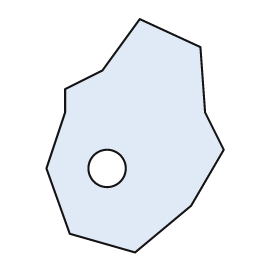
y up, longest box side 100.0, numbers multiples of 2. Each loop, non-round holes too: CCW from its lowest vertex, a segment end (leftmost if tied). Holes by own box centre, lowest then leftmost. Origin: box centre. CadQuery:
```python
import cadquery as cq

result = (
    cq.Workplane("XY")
    .moveTo(0.0, -50.0)
    .lineTo(24.0, -30.0)
    .lineTo(38.0, -6.0)
    .lineTo(30.0, 10.0)
    .lineTo(28.0, 38.0)
    .lineTo(2.0, 50.0)
    .lineTo(-14.0, 28.0)
    .lineTo(-30.0, 20.0)
    .lineTo(-30.0, 10.0)
    .lineTo(-38.0, -14.0)
    .lineTo(-28.0, -42.0)
    .close()
    .moveTo(-12.0, -14.0)
    .circle(8.0)
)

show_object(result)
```